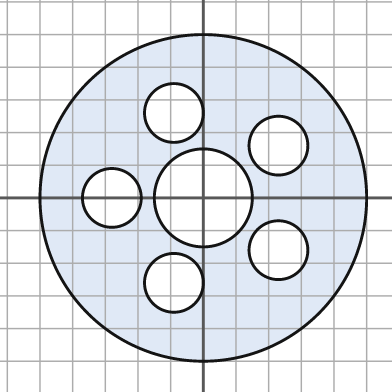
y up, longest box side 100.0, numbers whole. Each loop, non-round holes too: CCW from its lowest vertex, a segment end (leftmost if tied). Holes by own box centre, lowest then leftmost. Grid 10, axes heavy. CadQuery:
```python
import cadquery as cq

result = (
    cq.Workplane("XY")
    .moveTo(0.0, 0.0)
    .circle(50.0)
    .moveTo(-9.0, -26.0)
    .circle(9.0)
    .moveTo(23.0, -16.0)
    .circle(9.0)
    .moveTo(-28.0, 0.0)
    .circle(9.0)
    .moveTo(0.0, 0.0)
    .circle(15.0)
    .moveTo(23.0, 16.0)
    .circle(9.0)
    .moveTo(-9.0, 26.0)
    .circle(9.0)
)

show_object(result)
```